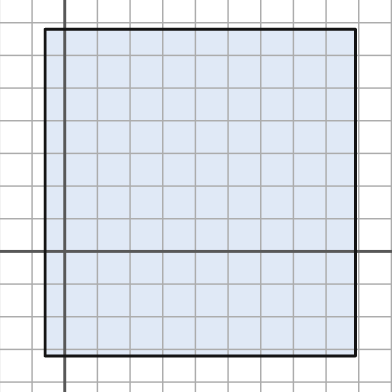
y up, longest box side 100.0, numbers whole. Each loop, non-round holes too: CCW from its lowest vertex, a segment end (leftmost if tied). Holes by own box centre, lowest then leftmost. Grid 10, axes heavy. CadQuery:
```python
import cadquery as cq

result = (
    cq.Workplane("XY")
    .moveTo(-6.0, -32.0)
    .lineTo(89.0, -32.0)
    .lineTo(89.0, 68.0)
    .lineTo(-6.0, 68.0)
    .close()
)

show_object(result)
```